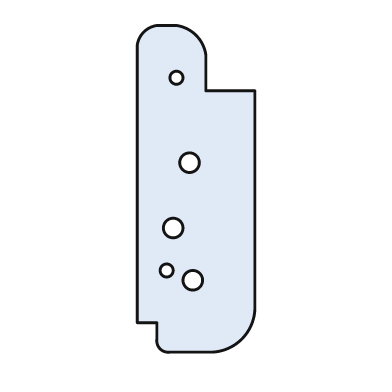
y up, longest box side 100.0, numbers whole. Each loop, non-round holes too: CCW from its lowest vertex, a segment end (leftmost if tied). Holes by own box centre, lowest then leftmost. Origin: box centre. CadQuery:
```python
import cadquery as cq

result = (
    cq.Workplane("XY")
    .moveTo(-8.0, -50.0)
    .lineTo(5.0, -50.0)
    .threePointArc((14.0, -46.0), (18.0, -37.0))
    .lineTo(18.0, 30.0)
    .lineTo(3.0, 30.0)
    .lineTo(3.0, 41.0)
    .threePointArc((0.0, 47.0), (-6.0, 50.0))
    .lineTo(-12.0, 50.0)
    .threePointArc((-16.0, 48.0), (-18.0, 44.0))
    .lineTo(-18.0, -41.0)
    .lineTo(-12.0, -41.0)
    .lineTo(-12.0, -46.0)
    .threePointArc((-11.0, -49.0), (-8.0, -50.0))
    .close()
    .moveTo(-1.0, -28.0)
    .circle(3.0)
    .moveTo(-9.0, -25.0)
    .circle(2.0)
    .moveTo(-7.0, -12.0)
    .circle(3.0)
    .moveTo(-2.0, 8.0)
    .circle(3.0)
    .moveTo(-6.0, 34.0)
    .circle(2.0)
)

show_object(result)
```